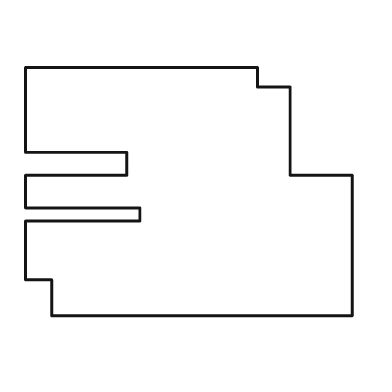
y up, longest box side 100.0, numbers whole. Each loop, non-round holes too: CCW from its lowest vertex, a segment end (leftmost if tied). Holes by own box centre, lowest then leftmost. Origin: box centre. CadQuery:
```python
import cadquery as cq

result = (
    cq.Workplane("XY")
    .moveTo(-42.0, -38.0)
    .lineTo(50.0, -38.0)
    .lineTo(50.0, 5.0)
    .lineTo(31.0, 5.0)
    .lineTo(31.0, 32.0)
    .lineTo(21.0, 32.0)
    .lineTo(21.0, 38.0)
    .lineTo(-50.0, 38.0)
    .lineTo(-50.0, 12.0)
    .lineTo(-19.0, 12.0)
    .lineTo(-19.0, 5.0)
    .lineTo(-50.0, 5.0)
    .lineTo(-50.0, -5.0)
    .lineTo(-15.0, -5.0)
    .lineTo(-15.0, -9.0)
    .lineTo(-50.0, -9.0)
    .lineTo(-50.0, -27.0)
    .lineTo(-42.0, -27.0)
    .close()
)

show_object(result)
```